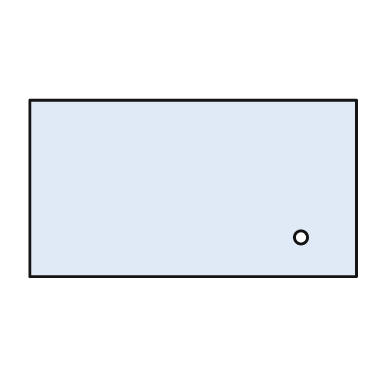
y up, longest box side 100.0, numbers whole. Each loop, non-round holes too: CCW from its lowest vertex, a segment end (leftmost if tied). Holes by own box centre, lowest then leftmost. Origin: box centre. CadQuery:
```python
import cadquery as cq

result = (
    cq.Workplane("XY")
    .moveTo(-50.0, -27.0)
    .lineTo(50.0, -27.0)
    .lineTo(50.0, 27.0)
    .lineTo(-50.0, 27.0)
    .close()
    .moveTo(33.0, -15.0)
    .circle(2.0)
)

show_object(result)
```